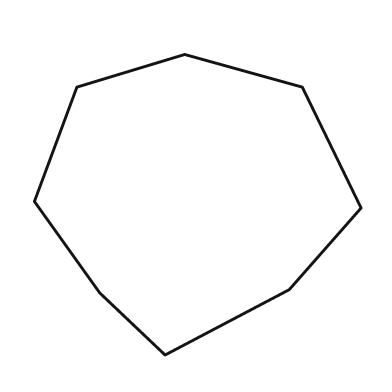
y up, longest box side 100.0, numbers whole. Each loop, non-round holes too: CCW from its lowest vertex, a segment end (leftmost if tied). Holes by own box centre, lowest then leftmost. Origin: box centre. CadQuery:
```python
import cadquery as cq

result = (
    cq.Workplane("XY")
    .moveTo(-10.0, -46.0)
    .lineTo(28.0, -26.0)
    .lineTo(50.0, -1.0)
    .lineTo(32.0, 36.0)
    .lineTo(-4.0, 46.0)
    .lineTo(-37.0, 36.0)
    .lineTo(-50.0, 1.0)
    .lineTo(-30.0, -27.0)
    .close()
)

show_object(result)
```